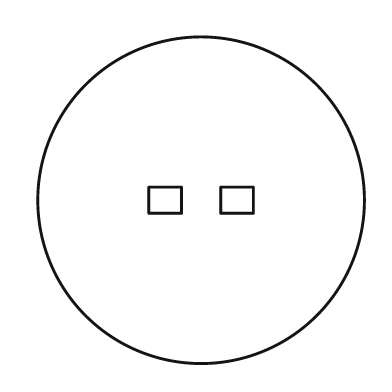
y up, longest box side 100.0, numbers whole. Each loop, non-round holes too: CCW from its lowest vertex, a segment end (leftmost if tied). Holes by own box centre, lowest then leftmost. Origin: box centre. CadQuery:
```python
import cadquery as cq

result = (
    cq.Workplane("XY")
    .moveTo(0.0, 0.0)
    .circle(50.0)
    .moveTo(-16.0, -4.0)
    .lineTo(-6.0, -4.0)
    .lineTo(-6.0, 4.0)
    .lineTo(-16.0, 4.0)
    .close()
    .moveTo(6.0, -4.0)
    .lineTo(16.0, -4.0)
    .lineTo(16.0, 4.0)
    .lineTo(6.0, 4.0)
    .close()
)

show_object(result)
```